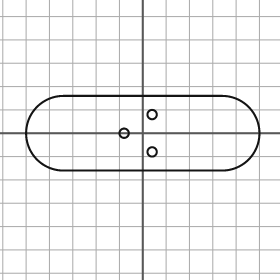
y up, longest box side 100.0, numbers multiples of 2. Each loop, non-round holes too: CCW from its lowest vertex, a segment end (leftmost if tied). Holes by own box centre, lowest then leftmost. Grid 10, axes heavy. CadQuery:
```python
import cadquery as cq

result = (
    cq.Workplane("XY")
    .moveTo(-34.0, -16.0)
    .lineTo(34.0, -16.0)
    .threePointArc((50.0, 0.0), (34.0, 16.0))
    .lineTo(-34.0, 16.0)
    .threePointArc((-50.0, 0.0), (-34.0, -16.0))
    .close()
    .moveTo(4.0, -8.0)
    .circle(2.0)
    .moveTo(-8.0, 0.0)
    .circle(2.0)
    .moveTo(4.0, 8.0)
    .circle(2.0)
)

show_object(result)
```